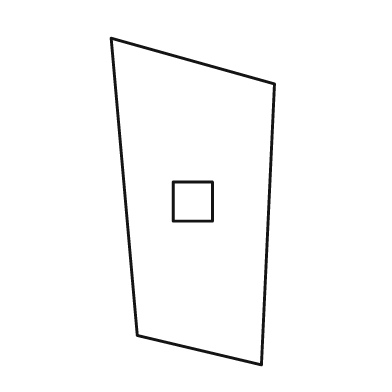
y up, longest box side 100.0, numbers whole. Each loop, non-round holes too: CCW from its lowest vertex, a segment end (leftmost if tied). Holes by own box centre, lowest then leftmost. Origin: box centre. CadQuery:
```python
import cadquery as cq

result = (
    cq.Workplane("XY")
    .moveTo(21.0, -50.0)
    .lineTo(25.0, 36.0)
    .lineTo(-25.0, 50.0)
    .lineTo(-17.0, -41.0)
    .close()
    .moveTo(-6.0, -6.0)
    .lineTo(6.0, -6.0)
    .lineTo(6.0, 6.0)
    .lineTo(-6.0, 6.0)
    .close()
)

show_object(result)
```